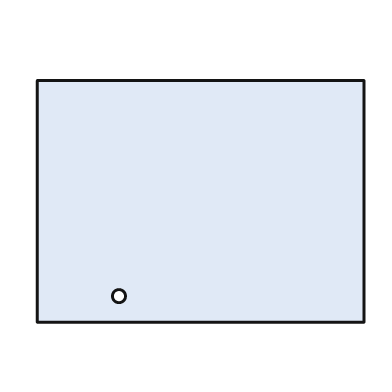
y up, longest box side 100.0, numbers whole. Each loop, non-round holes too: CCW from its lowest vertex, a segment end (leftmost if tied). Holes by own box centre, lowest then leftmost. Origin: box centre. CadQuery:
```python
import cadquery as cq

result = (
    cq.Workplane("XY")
    .moveTo(-50.0, -37.0)
    .lineTo(50.0, -37.0)
    .lineTo(50.0, 37.0)
    .lineTo(-50.0, 37.0)
    .close()
    .moveTo(-25.0, -29.0)
    .circle(2.0)
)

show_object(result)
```